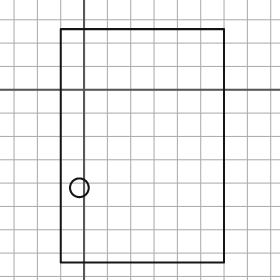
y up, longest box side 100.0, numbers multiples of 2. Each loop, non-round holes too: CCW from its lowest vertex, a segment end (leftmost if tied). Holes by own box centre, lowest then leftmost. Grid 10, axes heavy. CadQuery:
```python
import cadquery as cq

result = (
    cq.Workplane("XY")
    .moveTo(-10.0, -74.0)
    .lineTo(60.0, -74.0)
    .lineTo(60.0, 26.0)
    .lineTo(-10.0, 26.0)
    .close()
    .moveTo(-2.0, -42.0)
    .circle(4.0)
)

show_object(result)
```